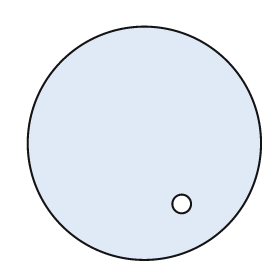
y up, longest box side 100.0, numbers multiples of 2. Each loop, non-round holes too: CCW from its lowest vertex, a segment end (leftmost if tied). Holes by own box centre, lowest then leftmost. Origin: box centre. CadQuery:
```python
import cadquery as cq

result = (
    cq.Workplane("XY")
    .moveTo(0.0, 0.0)
    .circle(50.0)
    .moveTo(16.0, -26.0)
    .circle(4.0)
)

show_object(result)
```